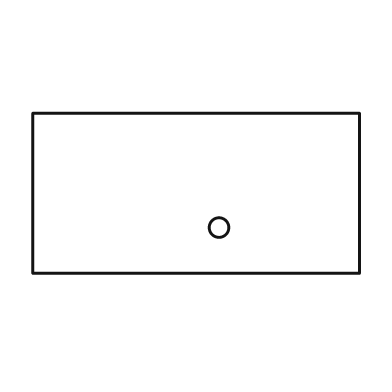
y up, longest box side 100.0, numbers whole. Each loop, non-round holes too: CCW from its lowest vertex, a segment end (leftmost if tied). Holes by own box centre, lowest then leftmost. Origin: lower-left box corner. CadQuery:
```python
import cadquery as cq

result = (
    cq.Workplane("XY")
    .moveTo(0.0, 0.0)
    .lineTo(100.0, 0.0)
    .lineTo(100.0, 49.0)
    .lineTo(0.0, 49.0)
    .close()
    .moveTo(57.0, 14.0)
    .circle(3.0)
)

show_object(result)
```